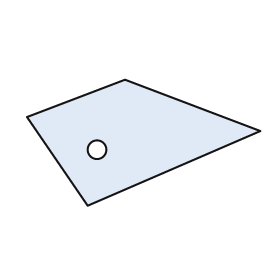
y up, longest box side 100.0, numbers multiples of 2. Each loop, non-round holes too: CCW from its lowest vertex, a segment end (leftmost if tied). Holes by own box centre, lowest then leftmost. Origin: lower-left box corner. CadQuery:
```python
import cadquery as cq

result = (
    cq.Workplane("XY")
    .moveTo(26.0, 0.0)
    .lineTo(100.0, 32.0)
    .lineTo(42.0, 54.0)
    .lineTo(0.0, 38.0)
    .close()
    .moveTo(30.0, 24.0)
    .circle(4.0)
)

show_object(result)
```